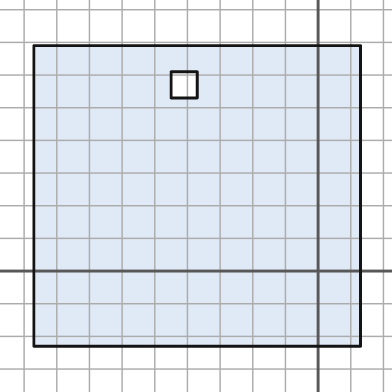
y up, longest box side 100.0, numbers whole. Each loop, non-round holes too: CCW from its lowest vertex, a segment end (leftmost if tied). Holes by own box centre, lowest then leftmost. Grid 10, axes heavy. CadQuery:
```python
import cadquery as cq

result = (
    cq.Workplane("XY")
    .moveTo(-87.0, -23.0)
    .lineTo(13.0, -23.0)
    .lineTo(13.0, 69.0)
    .lineTo(-87.0, 69.0)
    .close()
    .moveTo(-45.0, 53.0)
    .lineTo(-37.0, 53.0)
    .lineTo(-37.0, 61.0)
    .lineTo(-45.0, 61.0)
    .close()
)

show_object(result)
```